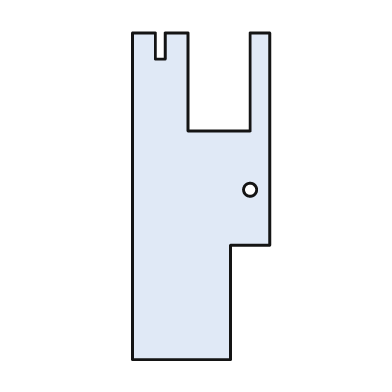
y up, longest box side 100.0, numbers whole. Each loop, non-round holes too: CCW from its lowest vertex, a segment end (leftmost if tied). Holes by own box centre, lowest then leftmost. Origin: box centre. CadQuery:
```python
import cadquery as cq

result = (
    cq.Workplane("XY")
    .moveTo(-21.0, -50.0)
    .lineTo(9.0, -50.0)
    .lineTo(9.0, -15.0)
    .lineTo(21.0, -15.0)
    .lineTo(21.0, 50.0)
    .lineTo(15.0, 50.0)
    .lineTo(15.0, 20.0)
    .lineTo(-4.0, 20.0)
    .lineTo(-4.0, 50.0)
    .lineTo(-11.0, 50.0)
    .lineTo(-11.0, 42.0)
    .lineTo(-14.0, 42.0)
    .lineTo(-14.0, 50.0)
    .lineTo(-21.0, 50.0)
    .close()
    .moveTo(15.0, 2.0)
    .circle(2.0)
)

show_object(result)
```